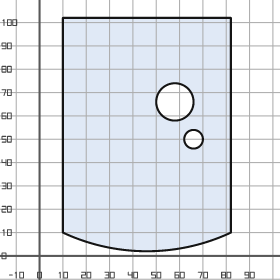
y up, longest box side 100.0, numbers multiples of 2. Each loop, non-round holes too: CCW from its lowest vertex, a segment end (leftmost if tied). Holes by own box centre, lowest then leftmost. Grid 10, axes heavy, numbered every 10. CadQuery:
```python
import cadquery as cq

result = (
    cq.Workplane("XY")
    .moveTo(10.0, 10.0)
    .threePointArc((46.0, 2.0), (82.0, 10.0))
    .lineTo(82.0, 102.0)
    .lineTo(10.0, 102.0)
    .close()
    .moveTo(66.0, 50.0)
    .circle(4.0)
    .moveTo(58.0, 66.0)
    .circle(8.0)
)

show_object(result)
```